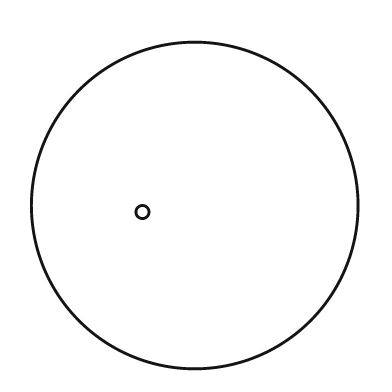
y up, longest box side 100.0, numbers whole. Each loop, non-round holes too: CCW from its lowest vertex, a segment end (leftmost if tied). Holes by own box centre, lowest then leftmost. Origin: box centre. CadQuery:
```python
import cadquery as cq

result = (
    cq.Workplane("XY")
    .moveTo(0.0, 0.0)
    .circle(50.0)
    .moveTo(-16.0, -2.0)
    .circle(2.0)
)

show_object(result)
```